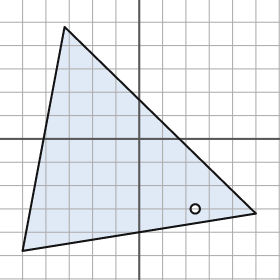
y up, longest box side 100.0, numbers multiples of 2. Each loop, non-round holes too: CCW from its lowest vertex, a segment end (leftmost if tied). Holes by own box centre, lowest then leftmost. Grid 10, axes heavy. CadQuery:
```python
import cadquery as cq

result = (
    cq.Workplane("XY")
    .moveTo(-50.0, -48.0)
    .lineTo(50.0, -32.0)
    .lineTo(-32.0, 48.0)
    .close()
    .moveTo(24.0, -30.0)
    .circle(2.0)
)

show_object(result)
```